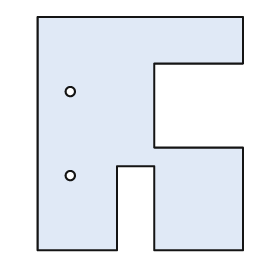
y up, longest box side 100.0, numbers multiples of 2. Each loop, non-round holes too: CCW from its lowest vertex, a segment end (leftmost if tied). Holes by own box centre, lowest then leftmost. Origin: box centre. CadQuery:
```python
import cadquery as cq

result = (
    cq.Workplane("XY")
    .moveTo(-44.0, -50.0)
    .lineTo(-10.0, -50.0)
    .lineTo(-10.0, -14.0)
    .lineTo(6.0, -14.0)
    .lineTo(6.0, -50.0)
    .lineTo(44.0, -50.0)
    .lineTo(44.0, -6.0)
    .lineTo(6.0, -6.0)
    .lineTo(6.0, 30.0)
    .lineTo(44.0, 30.0)
    .lineTo(44.0, 50.0)
    .lineTo(-44.0, 50.0)
    .close()
    .moveTo(-30.0, -18.0)
    .circle(2.0)
    .moveTo(-30.0, 18.0)
    .circle(2.0)
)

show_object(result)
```